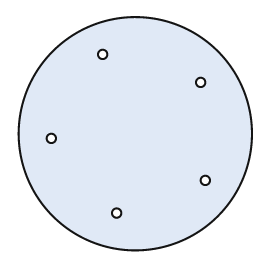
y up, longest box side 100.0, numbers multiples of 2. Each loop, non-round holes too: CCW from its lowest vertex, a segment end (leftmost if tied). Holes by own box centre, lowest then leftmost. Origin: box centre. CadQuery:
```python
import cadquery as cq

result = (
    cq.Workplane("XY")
    .moveTo(0.0, 0.0)
    .circle(50.0)
    .moveTo(-8.0, -34.0)
    .circle(2.0)
    .moveTo(30.0, -20.0)
    .circle(2.0)
    .moveTo(-36.0, -2.0)
    .circle(2.0)
    .moveTo(28.0, 22.0)
    .circle(2.0)
    .moveTo(-14.0, 34.0)
    .circle(2.0)
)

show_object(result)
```